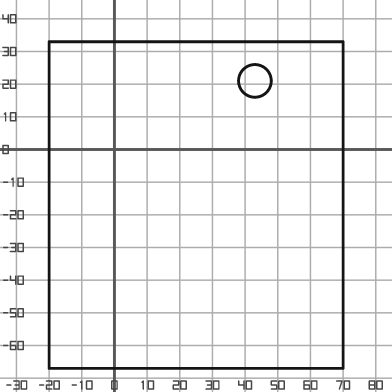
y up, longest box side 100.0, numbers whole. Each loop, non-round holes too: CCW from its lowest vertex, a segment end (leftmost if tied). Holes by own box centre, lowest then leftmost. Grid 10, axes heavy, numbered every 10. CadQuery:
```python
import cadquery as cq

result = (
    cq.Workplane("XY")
    .moveTo(-20.0, -67.0)
    .lineTo(70.0, -67.0)
    .lineTo(70.0, 33.0)
    .lineTo(-20.0, 33.0)
    .close()
    .moveTo(43.0, 21.0)
    .circle(5.0)
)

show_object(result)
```